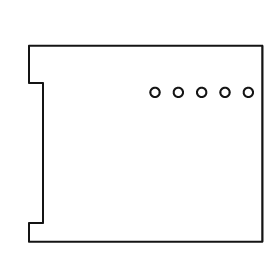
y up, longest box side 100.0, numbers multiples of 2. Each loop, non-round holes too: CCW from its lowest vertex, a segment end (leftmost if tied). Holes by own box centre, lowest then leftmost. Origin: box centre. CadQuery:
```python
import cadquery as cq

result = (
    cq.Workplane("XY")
    .moveTo(-50.0, -42.0)
    .lineTo(50.0, -42.0)
    .lineTo(50.0, 42.0)
    .lineTo(-50.0, 42.0)
    .lineTo(-50.0, 26.0)
    .lineTo(-44.0, 26.0)
    .lineTo(-44.0, -34.0)
    .lineTo(-50.0, -34.0)
    .close()
    .moveTo(4.0, 22.0)
    .circle(2.0)
    .moveTo(14.0, 22.0)
    .circle(2.0)
    .moveTo(24.0, 22.0)
    .circle(2.0)
    .moveTo(34.0, 22.0)
    .circle(2.0)
    .moveTo(44.0, 22.0)
    .circle(2.0)
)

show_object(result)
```